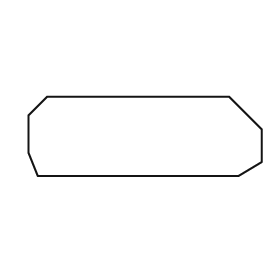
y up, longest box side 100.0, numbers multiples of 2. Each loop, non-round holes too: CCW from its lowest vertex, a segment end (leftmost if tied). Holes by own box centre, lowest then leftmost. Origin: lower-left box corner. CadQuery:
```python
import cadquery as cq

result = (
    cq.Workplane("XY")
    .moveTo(4.0, 0.0)
    .lineTo(90.0, 0.0)
    .lineTo(100.0, 6.0)
    .lineTo(100.0, 20.0)
    .lineTo(86.0, 34.0)
    .lineTo(8.0, 34.0)
    .lineTo(0.0, 26.0)
    .lineTo(0.0, 10.0)
    .close()
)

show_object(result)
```